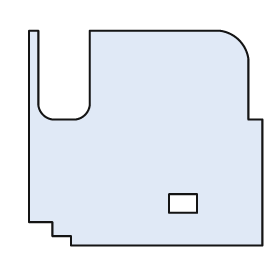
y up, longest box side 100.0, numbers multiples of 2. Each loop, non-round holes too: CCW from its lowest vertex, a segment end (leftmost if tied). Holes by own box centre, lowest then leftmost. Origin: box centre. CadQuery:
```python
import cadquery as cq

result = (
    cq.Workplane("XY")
    .moveTo(-32.0, -46.0)
    .lineTo(50.0, -46.0)
    .lineTo(50.0, 8.0)
    .lineTo(44.0, 8.0)
    .lineTo(44.0, 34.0)
    .threePointArc((40.0, 42.0), (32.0, 46.0))
    .lineTo(-24.0, 46.0)
    .lineTo(-24.0, 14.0)
    .threePointArc((-26.0, 10.0), (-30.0, 8.0))
    .lineTo(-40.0, 8.0)
    .threePointArc((-44.0, 10.0), (-46.0, 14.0))
    .lineTo(-46.0, 46.0)
    .lineTo(-50.0, 46.0)
    .lineTo(-50.0, -36.0)
    .lineTo(-40.0, -36.0)
    .lineTo(-40.0, -42.0)
    .lineTo(-32.0, -42.0)
    .close()
    .moveTo(10.0, -32.0)
    .lineTo(22.0, -32.0)
    .lineTo(22.0, -24.0)
    .lineTo(10.0, -24.0)
    .close()
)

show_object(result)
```